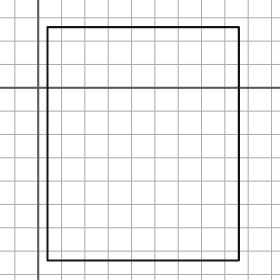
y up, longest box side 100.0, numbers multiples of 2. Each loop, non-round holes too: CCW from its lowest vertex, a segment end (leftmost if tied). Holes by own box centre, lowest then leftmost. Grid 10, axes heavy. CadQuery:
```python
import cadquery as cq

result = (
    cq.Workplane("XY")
    .moveTo(4.0, -74.0)
    .lineTo(86.0, -74.0)
    .lineTo(86.0, 26.0)
    .lineTo(4.0, 26.0)
    .close()
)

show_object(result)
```